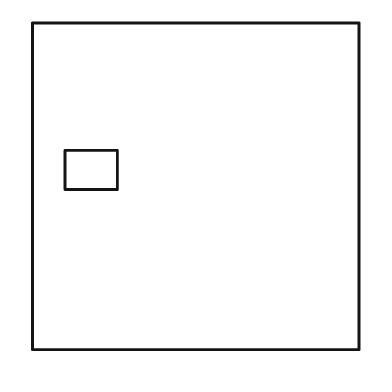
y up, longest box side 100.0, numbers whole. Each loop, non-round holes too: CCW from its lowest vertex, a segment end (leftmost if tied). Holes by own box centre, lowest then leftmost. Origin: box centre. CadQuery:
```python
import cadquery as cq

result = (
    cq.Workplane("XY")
    .moveTo(-50.0, -50.0)
    .lineTo(50.0, -50.0)
    .lineTo(50.0, 50.0)
    .lineTo(-50.0, 50.0)
    .close()
    .moveTo(-40.0, -1.0)
    .lineTo(-24.0, -1.0)
    .lineTo(-24.0, 11.0)
    .lineTo(-40.0, 11.0)
    .close()
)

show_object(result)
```